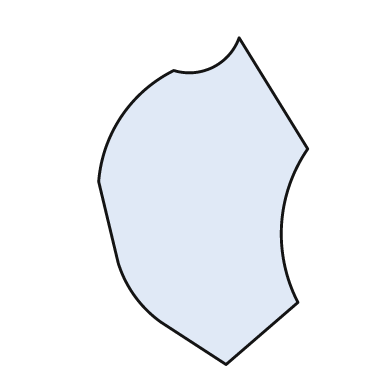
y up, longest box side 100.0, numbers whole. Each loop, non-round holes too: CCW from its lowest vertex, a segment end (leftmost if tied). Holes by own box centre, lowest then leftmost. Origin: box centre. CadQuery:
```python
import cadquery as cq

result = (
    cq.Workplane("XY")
    .moveTo(7.0, -50.0)
    .lineTo(29.0, -31.0)
    .threePointArc((24.0, -7.0), (32.0, 16.0))
    .lineTo(11.0, 50.0)
    .threePointArc((3.0, 41.0), (-9.0, 40.0))
    .threePointArc((-25.0, 26.0), (-32.0, 6.0))
    .lineTo(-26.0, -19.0)
    .threePointArc((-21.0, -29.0), (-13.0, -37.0))
    .close()
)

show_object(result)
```